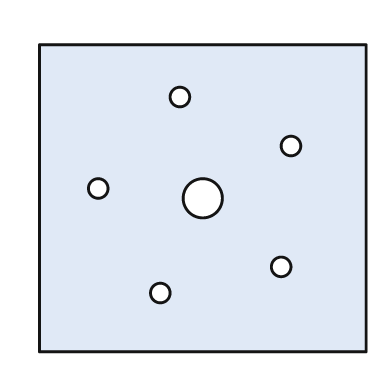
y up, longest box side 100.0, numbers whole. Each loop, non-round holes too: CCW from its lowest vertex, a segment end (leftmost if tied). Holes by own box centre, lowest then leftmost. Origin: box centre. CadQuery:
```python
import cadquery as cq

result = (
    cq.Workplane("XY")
    .moveTo(-50.0, -47.0)
    .lineTo(50.0, -47.0)
    .lineTo(50.0, 47.0)
    .lineTo(-50.0, 47.0)
    .close()
    .moveTo(-13.0, -29.0)
    .circle(3.0)
    .moveTo(24.0, -21.0)
    .circle(3.0)
    .moveTo(0.0, 0.0)
    .circle(6.0)
    .moveTo(-32.0, 3.0)
    .circle(3.0)
    .moveTo(27.0, 16.0)
    .circle(3.0)
    .moveTo(-7.0, 31.0)
    .circle(3.0)
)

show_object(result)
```